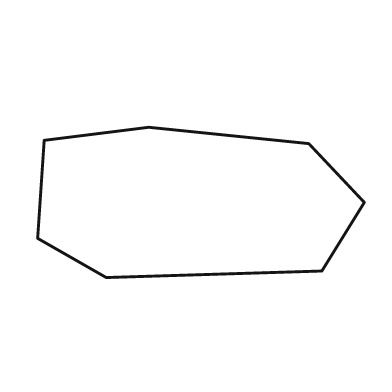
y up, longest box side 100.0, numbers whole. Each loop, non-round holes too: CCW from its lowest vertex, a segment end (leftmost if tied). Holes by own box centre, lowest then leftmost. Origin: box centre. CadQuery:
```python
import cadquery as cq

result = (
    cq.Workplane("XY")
    .moveTo(-29.0, -23.0)
    .lineTo(37.0, -21.0)
    .lineTo(50.0, 0.0)
    .lineTo(33.0, 18.0)
    .lineTo(-16.0, 23.0)
    .lineTo(-48.0, 19.0)
    .lineTo(-50.0, -11.0)
    .close()
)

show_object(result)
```